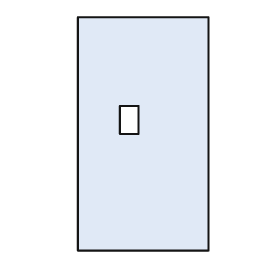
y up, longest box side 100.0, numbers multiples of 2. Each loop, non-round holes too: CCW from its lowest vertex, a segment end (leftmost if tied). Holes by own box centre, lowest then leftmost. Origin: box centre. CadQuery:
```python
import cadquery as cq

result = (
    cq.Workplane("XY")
    .moveTo(-28.0, -50.0)
    .lineTo(28.0, -50.0)
    .lineTo(28.0, 50.0)
    .lineTo(-28.0, 50.0)
    .close()
    .moveTo(-10.0, 0.0)
    .lineTo(-2.0, 0.0)
    .lineTo(-2.0, 12.0)
    .lineTo(-10.0, 12.0)
    .close()
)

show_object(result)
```